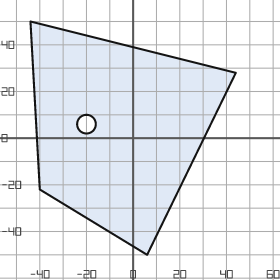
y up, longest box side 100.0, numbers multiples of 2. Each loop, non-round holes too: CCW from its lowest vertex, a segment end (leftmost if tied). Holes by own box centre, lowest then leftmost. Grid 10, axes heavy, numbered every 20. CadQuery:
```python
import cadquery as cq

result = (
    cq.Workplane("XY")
    .moveTo(6.0, -50.0)
    .lineTo(44.0, 28.0)
    .lineTo(-44.0, 50.0)
    .lineTo(-40.0, -22.0)
    .close()
    .moveTo(-20.0, 6.0)
    .circle(4.0)
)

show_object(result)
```